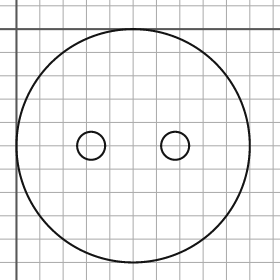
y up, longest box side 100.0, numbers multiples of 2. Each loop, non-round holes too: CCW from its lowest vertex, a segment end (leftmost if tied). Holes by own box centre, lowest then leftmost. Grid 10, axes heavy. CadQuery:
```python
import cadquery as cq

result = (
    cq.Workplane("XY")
    .moveTo(50.0, -50.0)
    .circle(50.0)
    .moveTo(32.0, -50.0)
    .circle(6.0)
    .moveTo(68.0, -50.0)
    .circle(6.0)
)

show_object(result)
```